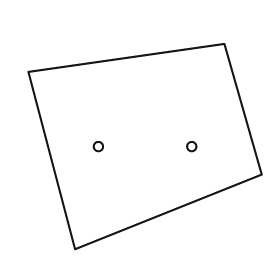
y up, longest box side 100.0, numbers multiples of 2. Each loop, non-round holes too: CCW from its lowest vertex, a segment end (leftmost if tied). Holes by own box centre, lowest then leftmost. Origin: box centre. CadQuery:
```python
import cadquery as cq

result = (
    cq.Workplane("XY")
    .moveTo(-30.0, -44.0)
    .lineTo(50.0, -12.0)
    .lineTo(34.0, 44.0)
    .lineTo(-50.0, 32.0)
    .close()
    .moveTo(-20.0, 0.0)
    .circle(2.0)
    .moveTo(20.0, 0.0)
    .circle(2.0)
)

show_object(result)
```